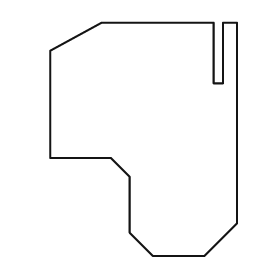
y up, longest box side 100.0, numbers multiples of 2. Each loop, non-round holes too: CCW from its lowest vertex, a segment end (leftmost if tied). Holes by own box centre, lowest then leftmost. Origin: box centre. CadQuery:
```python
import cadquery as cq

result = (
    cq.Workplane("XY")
    .moveTo(4.0, -50.0)
    .lineTo(26.0, -50.0)
    .lineTo(40.0, -36.0)
    .lineTo(40.0, 50.0)
    .lineTo(34.0, 50.0)
    .lineTo(34.0, 24.0)
    .lineTo(30.0, 24.0)
    .lineTo(30.0, 50.0)
    .lineTo(-18.0, 50.0)
    .lineTo(-40.0, 38.0)
    .lineTo(-40.0, -8.0)
    .lineTo(-14.0, -8.0)
    .lineTo(-6.0, -16.0)
    .lineTo(-6.0, -40.0)
    .close()
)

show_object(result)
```